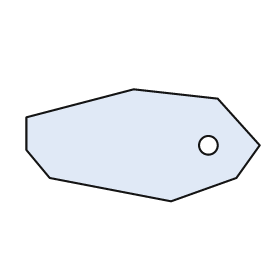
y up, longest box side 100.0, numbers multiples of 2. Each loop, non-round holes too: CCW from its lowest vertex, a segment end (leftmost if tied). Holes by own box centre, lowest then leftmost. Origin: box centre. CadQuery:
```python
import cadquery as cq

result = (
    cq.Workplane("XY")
    .moveTo(12.0, -24.0)
    .lineTo(40.0, -14.0)
    .lineTo(50.0, 0.0)
    .lineTo(32.0, 20.0)
    .lineTo(-4.0, 24.0)
    .lineTo(-50.0, 12.0)
    .lineTo(-50.0, -2.0)
    .lineTo(-40.0, -14.0)
    .close()
    .moveTo(28.0, 0.0)
    .circle(4.0)
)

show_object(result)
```